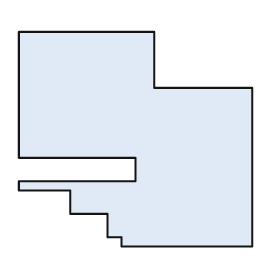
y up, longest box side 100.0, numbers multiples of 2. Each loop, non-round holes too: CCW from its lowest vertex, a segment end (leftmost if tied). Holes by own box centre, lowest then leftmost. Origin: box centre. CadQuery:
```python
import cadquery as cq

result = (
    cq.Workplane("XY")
    .moveTo(-6.0, -46.0)
    .lineTo(50.0, -46.0)
    .lineTo(50.0, 22.0)
    .lineTo(8.0, 22.0)
    .lineTo(8.0, 46.0)
    .lineTo(-50.0, 46.0)
    .lineTo(-50.0, -8.0)
    .lineTo(0.0, -8.0)
    .lineTo(0.0, -18.0)
    .lineTo(-50.0, -18.0)
    .lineTo(-50.0, -22.0)
    .lineTo(-28.0, -22.0)
    .lineTo(-28.0, -32.0)
    .lineTo(-12.0, -32.0)
    .lineTo(-12.0, -42.0)
    .lineTo(-6.0, -42.0)
    .close()
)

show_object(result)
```